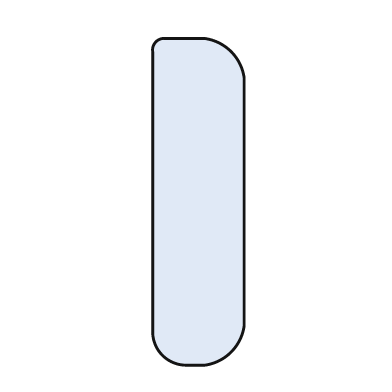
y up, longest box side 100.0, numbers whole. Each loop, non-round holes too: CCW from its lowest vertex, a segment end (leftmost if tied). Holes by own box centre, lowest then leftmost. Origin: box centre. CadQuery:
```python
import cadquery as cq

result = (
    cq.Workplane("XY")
    .moveTo(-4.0, -50.0)
    .lineTo(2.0, -50.0)
    .threePointArc((10.0, -46.0), (14.0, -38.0))
    .lineTo(14.0, 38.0)
    .threePointArc((10.0, 46.0), (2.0, 50.0))
    .lineTo(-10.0, 50.0)
    .threePointArc((-13.0, 49.0), (-14.0, 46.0))
    .lineTo(-14.0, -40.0)
    .threePointArc((-11.0, -47.0), (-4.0, -50.0))
    .close()
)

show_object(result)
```